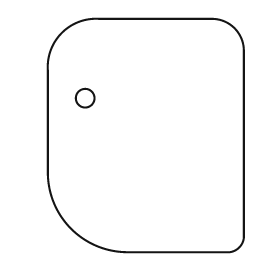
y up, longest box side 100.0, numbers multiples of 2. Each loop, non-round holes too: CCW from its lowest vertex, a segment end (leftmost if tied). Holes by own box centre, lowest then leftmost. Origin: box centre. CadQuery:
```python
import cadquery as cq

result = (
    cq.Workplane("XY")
    .moveTo(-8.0, -50.0)
    .lineTo(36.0, -50.0)
    .threePointArc((40.0, -48.0), (42.0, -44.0))
    .lineTo(42.0, 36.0)
    .threePointArc((38.0, 46.0), (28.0, 50.0))
    .lineTo(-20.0, 50.0)
    .threePointArc((-36.0, 44.0), (-42.0, 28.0))
    .lineTo(-42.0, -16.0)
    .threePointArc((-32.0, -40.0), (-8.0, -50.0))
    .close()
    .moveTo(-26.0, 16.0)
    .circle(4.0)
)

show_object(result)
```